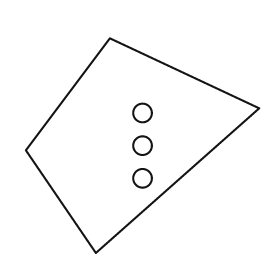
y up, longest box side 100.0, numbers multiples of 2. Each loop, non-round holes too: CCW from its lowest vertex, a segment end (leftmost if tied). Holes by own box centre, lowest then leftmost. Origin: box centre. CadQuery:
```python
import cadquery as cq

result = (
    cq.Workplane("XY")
    .moveTo(-20.0, -46.0)
    .lineTo(50.0, 16.0)
    .lineTo(-14.0, 46.0)
    .lineTo(-50.0, -2.0)
    .close()
    .moveTo(0.0, -14.0)
    .circle(4.0)
    .moveTo(0.0, 0.0)
    .circle(4.0)
    .moveTo(0.0, 14.0)
    .circle(4.0)
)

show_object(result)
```